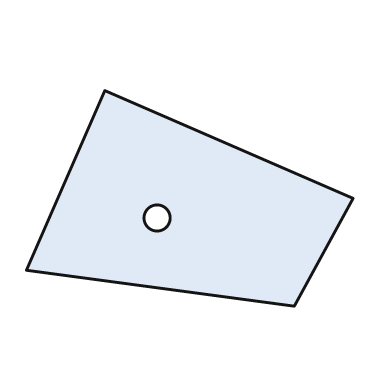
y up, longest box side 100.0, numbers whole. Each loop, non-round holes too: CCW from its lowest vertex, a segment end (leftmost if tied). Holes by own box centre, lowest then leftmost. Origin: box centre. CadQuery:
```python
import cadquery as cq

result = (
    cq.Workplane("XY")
    .moveTo(32.0, -33.0)
    .lineTo(50.0, 0.0)
    .lineTo(-26.0, 33.0)
    .lineTo(-50.0, -22.0)
    .close()
    .moveTo(-10.0, -6.0)
    .circle(4.0)
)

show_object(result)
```